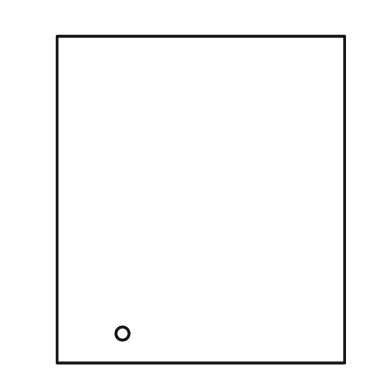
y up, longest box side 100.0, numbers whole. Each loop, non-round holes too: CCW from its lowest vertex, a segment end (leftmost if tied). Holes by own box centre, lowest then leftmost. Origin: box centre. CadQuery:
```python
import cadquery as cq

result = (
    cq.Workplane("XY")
    .moveTo(-44.0, -50.0)
    .lineTo(44.0, -50.0)
    .lineTo(44.0, 50.0)
    .lineTo(-44.0, 50.0)
    .close()
    .moveTo(-24.0, -41.0)
    .circle(2.0)
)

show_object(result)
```